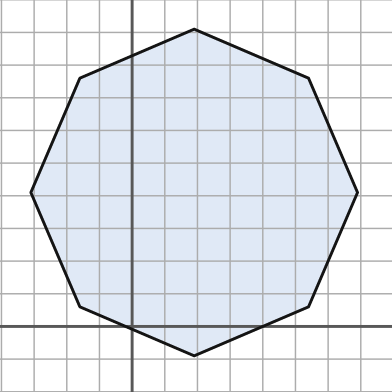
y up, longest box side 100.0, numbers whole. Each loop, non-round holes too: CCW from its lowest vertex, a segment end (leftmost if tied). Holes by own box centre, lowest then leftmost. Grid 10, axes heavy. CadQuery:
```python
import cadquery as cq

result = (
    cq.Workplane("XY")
    .moveTo(19.0, -9.0)
    .lineTo(54.0, 6.0)
    .lineTo(69.0, 41.0)
    .lineTo(54.0, 76.0)
    .lineTo(19.0, 91.0)
    .lineTo(-16.0, 76.0)
    .lineTo(-31.0, 41.0)
    .lineTo(-16.0, 6.0)
    .close()
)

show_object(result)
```